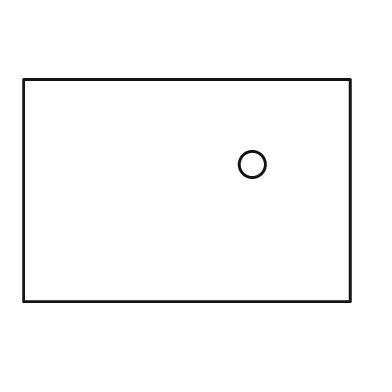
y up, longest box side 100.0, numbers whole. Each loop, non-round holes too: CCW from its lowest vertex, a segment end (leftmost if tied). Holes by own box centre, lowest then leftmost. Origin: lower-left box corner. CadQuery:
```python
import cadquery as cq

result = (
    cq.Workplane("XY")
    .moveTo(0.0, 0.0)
    .lineTo(100.0, 0.0)
    .lineTo(100.0, 68.0)
    .lineTo(0.0, 68.0)
    .close()
    .moveTo(70.0, 42.0)
    .circle(4.0)
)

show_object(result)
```